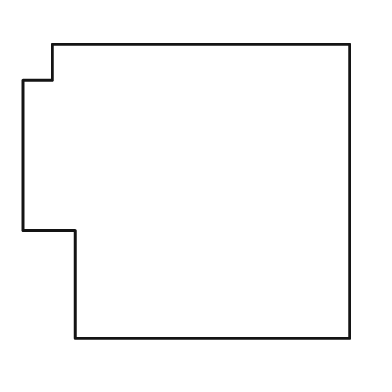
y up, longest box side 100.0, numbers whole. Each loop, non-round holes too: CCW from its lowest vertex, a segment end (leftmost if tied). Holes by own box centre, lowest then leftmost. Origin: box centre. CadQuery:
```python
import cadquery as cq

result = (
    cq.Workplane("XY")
    .moveTo(-34.0, -45.0)
    .lineTo(50.0, -45.0)
    .lineTo(50.0, 45.0)
    .lineTo(-41.0, 45.0)
    .lineTo(-41.0, 34.0)
    .lineTo(-50.0, 34.0)
    .lineTo(-50.0, -12.0)
    .lineTo(-34.0, -12.0)
    .close()
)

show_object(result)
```